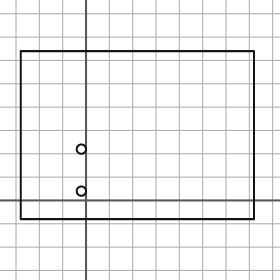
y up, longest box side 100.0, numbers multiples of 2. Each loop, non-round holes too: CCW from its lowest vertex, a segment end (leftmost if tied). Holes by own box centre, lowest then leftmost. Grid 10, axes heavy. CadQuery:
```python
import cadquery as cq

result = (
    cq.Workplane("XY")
    .moveTo(-28.0, -8.0)
    .lineTo(72.0, -8.0)
    .lineTo(72.0, 64.0)
    .lineTo(-28.0, 64.0)
    .close()
    .moveTo(-2.0, 4.0)
    .circle(2.0)
    .moveTo(-2.0, 22.0)
    .circle(2.0)
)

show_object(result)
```